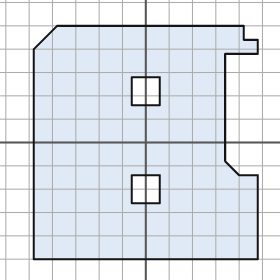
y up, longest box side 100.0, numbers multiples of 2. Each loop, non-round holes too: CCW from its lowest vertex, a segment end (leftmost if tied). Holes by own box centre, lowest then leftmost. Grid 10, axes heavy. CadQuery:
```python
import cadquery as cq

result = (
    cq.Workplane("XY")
    .moveTo(-48.0, -50.0)
    .lineTo(48.0, -50.0)
    .lineTo(48.0, -14.0)
    .lineTo(40.0, -14.0)
    .lineTo(34.0, -8.0)
    .lineTo(34.0, 38.0)
    .lineTo(48.0, 38.0)
    .lineTo(48.0, 44.0)
    .lineTo(42.0, 44.0)
    .lineTo(42.0, 50.0)
    .lineTo(-38.0, 50.0)
    .lineTo(-48.0, 40.0)
    .close()
    .moveTo(-6.0, -26.0)
    .lineTo(6.0, -26.0)
    .lineTo(6.0, -14.0)
    .lineTo(-6.0, -14.0)
    .close()
    .moveTo(-6.0, 16.0)
    .lineTo(6.0, 16.0)
    .lineTo(6.0, 28.0)
    .lineTo(-6.0, 28.0)
    .close()
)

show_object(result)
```